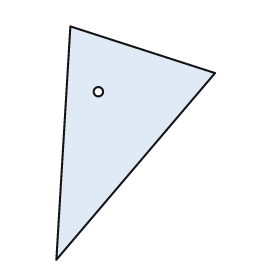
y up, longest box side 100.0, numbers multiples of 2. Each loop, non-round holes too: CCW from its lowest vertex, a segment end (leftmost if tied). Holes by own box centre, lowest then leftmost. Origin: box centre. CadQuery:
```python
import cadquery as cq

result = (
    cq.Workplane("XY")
    .moveTo(-34.0, -50.0)
    .lineTo(34.0, 30.0)
    .lineTo(-28.0, 50.0)
    .close()
    .moveTo(-16.0, 22.0)
    .circle(2.0)
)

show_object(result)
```